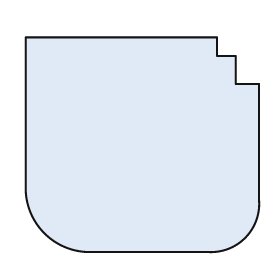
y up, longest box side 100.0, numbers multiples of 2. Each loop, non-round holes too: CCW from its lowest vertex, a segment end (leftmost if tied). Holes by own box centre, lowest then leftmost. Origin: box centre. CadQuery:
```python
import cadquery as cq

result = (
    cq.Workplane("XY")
    .moveTo(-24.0, -46.0)
    .lineTo(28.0, -46.0)
    .threePointArc((44.0, -40.0), (50.0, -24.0))
    .lineTo(50.0, 26.0)
    .lineTo(40.0, 26.0)
    .lineTo(40.0, 38.0)
    .lineTo(32.0, 38.0)
    .lineTo(32.0, 46.0)
    .lineTo(-50.0, 46.0)
    .lineTo(-50.0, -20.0)
    .threePointArc((-42.0, -38.0), (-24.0, -46.0))
    .close()
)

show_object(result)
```